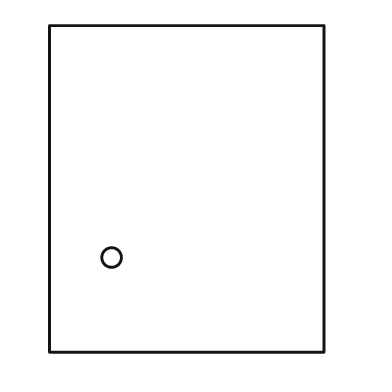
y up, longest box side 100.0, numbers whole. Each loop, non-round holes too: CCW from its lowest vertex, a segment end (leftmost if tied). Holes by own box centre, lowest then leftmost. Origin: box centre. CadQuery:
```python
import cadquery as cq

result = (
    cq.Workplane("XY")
    .moveTo(-42.0, -50.0)
    .lineTo(42.0, -50.0)
    .lineTo(42.0, 50.0)
    .lineTo(-42.0, 50.0)
    .close()
    .moveTo(-23.0, -21.0)
    .circle(3.0)
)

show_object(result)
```